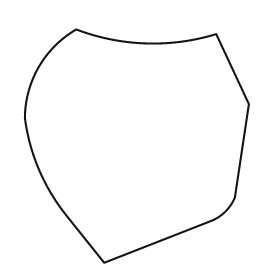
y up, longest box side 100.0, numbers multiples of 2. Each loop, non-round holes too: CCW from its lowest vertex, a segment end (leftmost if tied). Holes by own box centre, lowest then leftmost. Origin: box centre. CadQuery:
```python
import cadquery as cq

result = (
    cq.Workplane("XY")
    .moveTo(-14.0, -50.0)
    .lineTo(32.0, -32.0)
    .threePointArc((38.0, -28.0), (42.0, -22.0))
    .lineTo(48.0, 18.0)
    .lineTo(34.0, 48.0)
    .threePointArc((4.0, 44.0), (-26.0, 50.0))
    .threePointArc((-42.0, 34.0), (-48.0, 12.0))
    .threePointArc((-42.0, -10.0), (-30.0, -30.0))
    .close()
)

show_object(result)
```